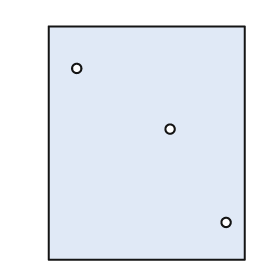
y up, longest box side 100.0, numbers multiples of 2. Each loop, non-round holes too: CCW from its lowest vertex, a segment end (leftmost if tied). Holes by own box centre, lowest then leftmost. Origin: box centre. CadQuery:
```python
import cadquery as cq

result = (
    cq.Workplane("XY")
    .moveTo(-42.0, -50.0)
    .lineTo(42.0, -50.0)
    .lineTo(42.0, 50.0)
    .lineTo(-42.0, 50.0)
    .close()
    .moveTo(34.0, -34.0)
    .circle(2.0)
    .moveTo(10.0, 6.0)
    .circle(2.0)
    .moveTo(-30.0, 32.0)
    .circle(2.0)
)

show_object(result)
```